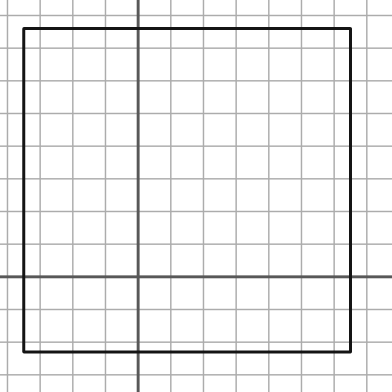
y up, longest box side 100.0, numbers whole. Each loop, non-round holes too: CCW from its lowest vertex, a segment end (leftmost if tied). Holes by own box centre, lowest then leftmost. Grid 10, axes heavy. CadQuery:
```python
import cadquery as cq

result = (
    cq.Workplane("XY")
    .moveTo(-35.0, -23.0)
    .lineTo(65.0, -23.0)
    .lineTo(65.0, 76.0)
    .lineTo(-35.0, 76.0)
    .close()
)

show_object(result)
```